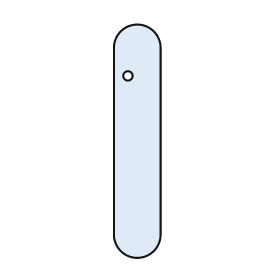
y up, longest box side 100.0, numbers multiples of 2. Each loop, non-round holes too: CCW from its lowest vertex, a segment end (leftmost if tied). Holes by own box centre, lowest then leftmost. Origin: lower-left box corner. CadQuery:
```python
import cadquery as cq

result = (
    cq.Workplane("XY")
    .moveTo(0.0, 10.0)
    .threePointArc((10.0, 0.0), (20.0, 10.0))
    .lineTo(20.0, 90.0)
    .threePointArc((10.0, 100.0), (0.0, 90.0))
    .close()
    .moveTo(6.0, 78.0)
    .circle(2.0)
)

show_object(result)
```